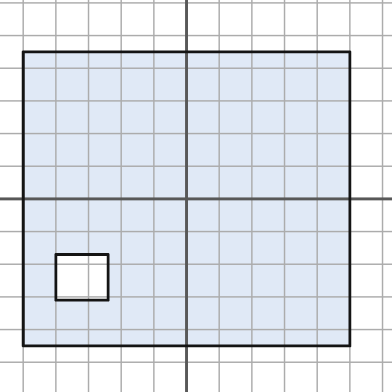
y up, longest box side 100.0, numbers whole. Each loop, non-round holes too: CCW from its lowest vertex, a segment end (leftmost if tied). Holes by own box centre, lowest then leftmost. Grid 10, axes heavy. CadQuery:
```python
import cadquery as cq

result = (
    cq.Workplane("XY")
    .moveTo(-50.0, -45.0)
    .lineTo(50.0, -45.0)
    .lineTo(50.0, 45.0)
    .lineTo(-50.0, 45.0)
    .close()
    .moveTo(-40.0, -31.0)
    .lineTo(-24.0, -31.0)
    .lineTo(-24.0, -17.0)
    .lineTo(-40.0, -17.0)
    .close()
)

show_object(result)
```